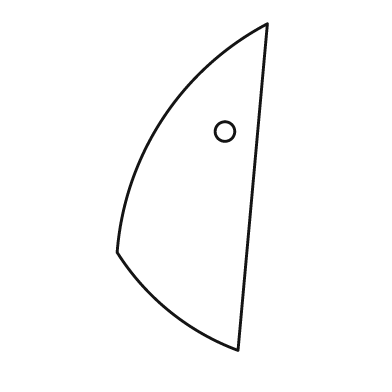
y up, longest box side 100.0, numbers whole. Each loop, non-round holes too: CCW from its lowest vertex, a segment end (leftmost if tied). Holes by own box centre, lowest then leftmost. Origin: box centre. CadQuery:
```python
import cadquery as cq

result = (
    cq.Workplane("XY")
    .moveTo(14.0, -50.0)
    .lineTo(23.0, 50.0)
    .threePointArc((-9.0, 21.0), (-23.0, -20.0))
    .threePointArc((-7.0, -38.0), (14.0, -50.0))
    .close()
    .moveTo(10.0, 17.0)
    .circle(3.0)
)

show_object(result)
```